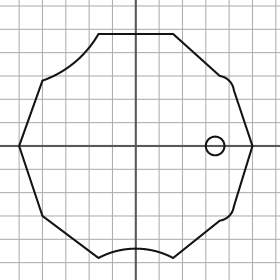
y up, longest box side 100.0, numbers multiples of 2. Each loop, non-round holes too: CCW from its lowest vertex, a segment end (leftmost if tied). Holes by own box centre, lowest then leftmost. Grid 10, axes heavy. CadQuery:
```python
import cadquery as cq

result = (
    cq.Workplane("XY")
    .moveTo(-16.0, -48.0)
    .threePointArc((0.0, -44.0), (16.0, -48.0))
    .lineTo(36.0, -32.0)
    .threePointArc((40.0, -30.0), (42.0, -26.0))
    .lineTo(50.0, 0.0)
    .lineTo(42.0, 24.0)
    .threePointArc((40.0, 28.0), (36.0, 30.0))
    .lineTo(16.0, 48.0)
    .lineTo(-16.0, 48.0)
    .threePointArc((-26.0, 36.0), (-40.0, 28.0))
    .lineTo(-50.0, 0.0)
    .lineTo(-40.0, -30.0)
    .close()
    .moveTo(34.0, 0.0)
    .circle(4.0)
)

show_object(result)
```